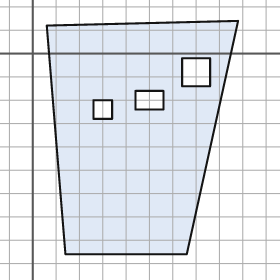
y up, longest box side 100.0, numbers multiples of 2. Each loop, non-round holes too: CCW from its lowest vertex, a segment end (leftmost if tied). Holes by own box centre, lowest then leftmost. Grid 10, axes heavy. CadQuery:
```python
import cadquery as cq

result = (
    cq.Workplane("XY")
    .moveTo(14.0, -86.0)
    .lineTo(66.0, -86.0)
    .lineTo(88.0, 14.0)
    .lineTo(6.0, 12.0)
    .close()
    .moveTo(26.0, -28.0)
    .lineTo(34.0, -28.0)
    .lineTo(34.0, -20.0)
    .lineTo(26.0, -20.0)
    .close()
    .moveTo(44.0, -24.0)
    .lineTo(56.0, -24.0)
    .lineTo(56.0, -16.0)
    .lineTo(44.0, -16.0)
    .close()
    .moveTo(64.0, -14.0)
    .lineTo(76.0, -14.0)
    .lineTo(76.0, -2.0)
    .lineTo(64.0, -2.0)
    .close()
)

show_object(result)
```